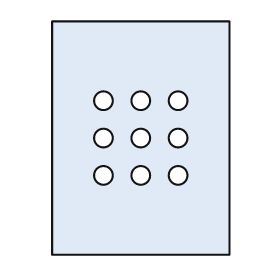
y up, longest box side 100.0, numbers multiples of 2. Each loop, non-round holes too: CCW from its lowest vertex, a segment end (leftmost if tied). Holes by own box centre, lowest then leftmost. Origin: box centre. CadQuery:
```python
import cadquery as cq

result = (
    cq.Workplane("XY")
    .moveTo(-38.0, -50.0)
    .lineTo(38.0, -50.0)
    .lineTo(38.0, 50.0)
    .lineTo(-38.0, 50.0)
    .close()
    .moveTo(-16.0, -16.0)
    .circle(4.0)
    .moveTo(0.0, -16.0)
    .circle(4.0)
    .moveTo(16.0, -16.0)
    .circle(4.0)
    .moveTo(-16.0, 0.0)
    .circle(4.0)
    .moveTo(0.0, 0.0)
    .circle(4.0)
    .moveTo(16.0, 0.0)
    .circle(4.0)
    .moveTo(-16.0, 16.0)
    .circle(4.0)
    .moveTo(0.0, 16.0)
    .circle(4.0)
    .moveTo(16.0, 16.0)
    .circle(4.0)
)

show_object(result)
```